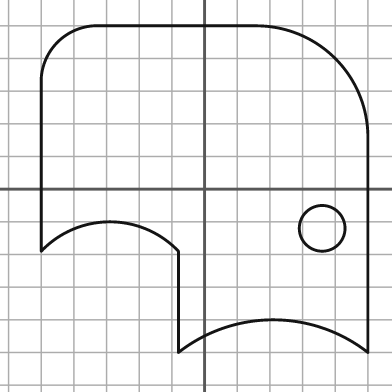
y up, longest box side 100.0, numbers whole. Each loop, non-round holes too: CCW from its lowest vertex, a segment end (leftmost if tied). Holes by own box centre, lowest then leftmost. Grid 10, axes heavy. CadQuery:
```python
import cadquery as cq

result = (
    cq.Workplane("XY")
    .moveTo(-8.0, -50.0)
    .threePointArc((21.0, -40.0), (50.0, -50.0))
    .lineTo(50.0, 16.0)
    .threePointArc((40.0, 40.0), (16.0, 50.0))
    .lineTo(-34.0, 50.0)
    .threePointArc((-45.0, 45.0), (-50.0, 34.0))
    .lineTo(-50.0, -19.0)
    .threePointArc((-29.0, -10.0), (-8.0, -19.0))
    .close()
    .moveTo(36.0, -12.0)
    .circle(7.0)
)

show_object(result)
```